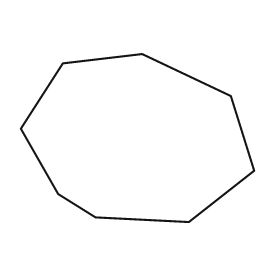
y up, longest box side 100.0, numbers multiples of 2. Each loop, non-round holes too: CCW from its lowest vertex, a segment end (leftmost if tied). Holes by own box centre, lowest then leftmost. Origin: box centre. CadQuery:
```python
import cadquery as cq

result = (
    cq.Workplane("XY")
    .moveTo(22.0, -36.0)
    .lineTo(50.0, -14.0)
    .lineTo(40.0, 18.0)
    .lineTo(2.0, 36.0)
    .lineTo(-32.0, 32.0)
    .lineTo(-50.0, 4.0)
    .lineTo(-34.0, -24.0)
    .lineTo(-18.0, -34.0)
    .close()
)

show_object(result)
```